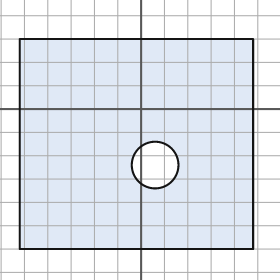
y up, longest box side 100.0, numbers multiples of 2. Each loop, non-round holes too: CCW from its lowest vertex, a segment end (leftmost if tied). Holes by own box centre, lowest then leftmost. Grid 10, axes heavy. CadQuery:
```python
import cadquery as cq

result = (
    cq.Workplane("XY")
    .moveTo(-52.0, -60.0)
    .lineTo(48.0, -60.0)
    .lineTo(48.0, 30.0)
    .lineTo(-52.0, 30.0)
    .close()
    .moveTo(6.0, -24.0)
    .circle(10.0)
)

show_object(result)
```